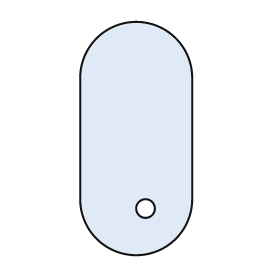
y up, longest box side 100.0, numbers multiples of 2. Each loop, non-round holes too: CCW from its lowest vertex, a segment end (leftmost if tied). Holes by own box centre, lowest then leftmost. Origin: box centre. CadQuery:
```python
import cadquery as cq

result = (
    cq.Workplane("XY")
    .moveTo(-24.0, -26.0)
    .threePointArc((0.0, -50.0), (24.0, -26.0))
    .lineTo(24.0, 26.0)
    .threePointArc((0.0, 50.0), (-24.0, 26.0))
    .close()
    .moveTo(4.0, -30.0)
    .circle(4.0)
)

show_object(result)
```